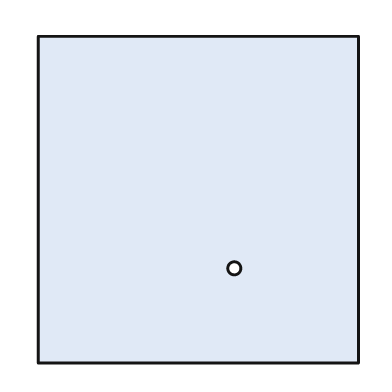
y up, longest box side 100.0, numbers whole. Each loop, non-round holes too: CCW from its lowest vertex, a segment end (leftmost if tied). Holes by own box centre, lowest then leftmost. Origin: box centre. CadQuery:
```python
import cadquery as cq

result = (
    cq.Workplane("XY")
    .moveTo(-49.0, -50.0)
    .lineTo(49.0, -50.0)
    .lineTo(49.0, 50.0)
    .lineTo(-49.0, 50.0)
    .close()
    .moveTo(11.0, -21.0)
    .circle(2.0)
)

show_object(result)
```